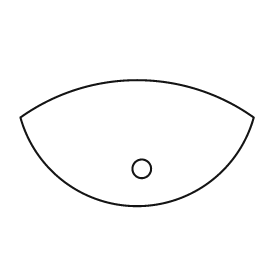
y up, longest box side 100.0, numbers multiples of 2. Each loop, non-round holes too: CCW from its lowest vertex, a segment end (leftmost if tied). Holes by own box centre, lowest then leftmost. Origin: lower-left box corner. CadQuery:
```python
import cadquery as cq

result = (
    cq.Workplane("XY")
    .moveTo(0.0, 38.0)
    .threePointArc((50.0, 0.0), (100.0, 38.0))
    .threePointArc((50.0, 54.0), (0.0, 38.0))
    .close()
    .moveTo(52.0, 16.0)
    .circle(4.0)
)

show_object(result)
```